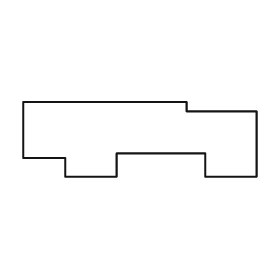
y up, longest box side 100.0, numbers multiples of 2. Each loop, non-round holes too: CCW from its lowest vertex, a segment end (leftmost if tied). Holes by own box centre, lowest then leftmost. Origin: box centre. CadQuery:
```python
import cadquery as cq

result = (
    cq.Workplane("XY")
    .moveTo(-32.0, -16.0)
    .lineTo(-10.0, -16.0)
    .lineTo(-10.0, -6.0)
    .lineTo(28.0, -6.0)
    .lineTo(28.0, -16.0)
    .lineTo(50.0, -16.0)
    .lineTo(50.0, 12.0)
    .lineTo(20.0, 12.0)
    .lineTo(20.0, 16.0)
    .lineTo(-50.0, 16.0)
    .lineTo(-50.0, -8.0)
    .lineTo(-32.0, -8.0)
    .close()
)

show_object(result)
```